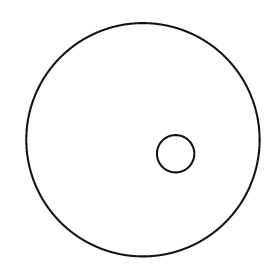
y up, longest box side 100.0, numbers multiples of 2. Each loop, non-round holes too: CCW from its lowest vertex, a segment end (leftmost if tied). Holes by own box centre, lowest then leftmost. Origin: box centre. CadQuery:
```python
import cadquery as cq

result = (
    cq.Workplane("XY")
    .moveTo(0.0, 0.0)
    .circle(50.0)
    .moveTo(14.0, -6.0)
    .circle(8.0)
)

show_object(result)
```